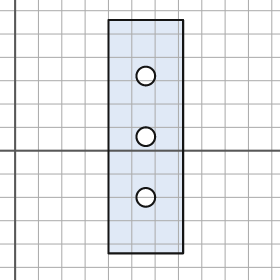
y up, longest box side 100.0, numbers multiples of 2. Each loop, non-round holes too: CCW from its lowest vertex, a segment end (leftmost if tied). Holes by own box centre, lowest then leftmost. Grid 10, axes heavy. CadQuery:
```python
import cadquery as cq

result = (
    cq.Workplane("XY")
    .moveTo(40.0, -44.0)
    .lineTo(72.0, -44.0)
    .lineTo(72.0, 56.0)
    .lineTo(40.0, 56.0)
    .close()
    .moveTo(56.0, -20.0)
    .circle(4.0)
    .moveTo(56.0, 6.0)
    .circle(4.0)
    .moveTo(56.0, 32.0)
    .circle(4.0)
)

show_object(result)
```